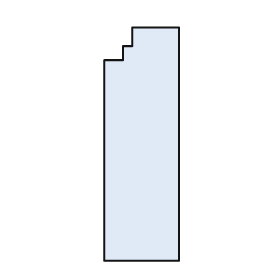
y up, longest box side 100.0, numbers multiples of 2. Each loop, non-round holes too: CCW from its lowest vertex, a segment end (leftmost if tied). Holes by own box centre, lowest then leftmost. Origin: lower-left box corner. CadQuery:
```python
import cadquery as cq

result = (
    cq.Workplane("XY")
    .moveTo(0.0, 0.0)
    .lineTo(32.0, 0.0)
    .lineTo(32.0, 100.0)
    .lineTo(12.0, 100.0)
    .lineTo(12.0, 92.0)
    .lineTo(8.0, 92.0)
    .lineTo(8.0, 86.0)
    .lineTo(0.0, 86.0)
    .close()
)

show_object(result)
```